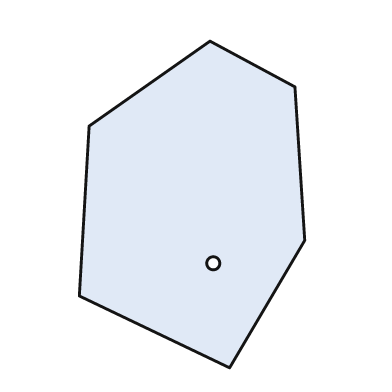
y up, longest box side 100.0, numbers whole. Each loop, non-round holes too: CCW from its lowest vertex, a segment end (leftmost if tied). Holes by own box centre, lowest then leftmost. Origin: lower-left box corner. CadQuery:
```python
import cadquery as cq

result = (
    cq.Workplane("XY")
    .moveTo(46.0, 0.0)
    .lineTo(69.0, 39.0)
    .lineTo(66.0, 86.0)
    .lineTo(40.0, 100.0)
    .lineTo(3.0, 74.0)
    .lineTo(0.0, 22.0)
    .close()
    .moveTo(41.0, 32.0)
    .circle(2.0)
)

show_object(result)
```